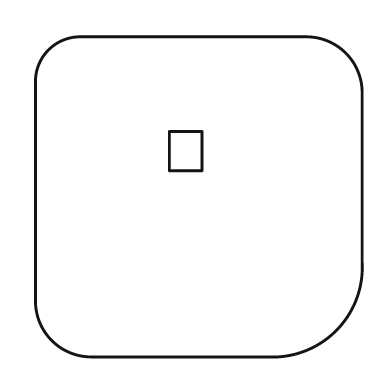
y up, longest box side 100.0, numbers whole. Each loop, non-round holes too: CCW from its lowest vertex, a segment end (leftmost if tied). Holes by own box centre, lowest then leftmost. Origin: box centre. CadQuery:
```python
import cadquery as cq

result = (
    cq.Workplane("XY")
    .moveTo(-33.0, -49.0)
    .lineTo(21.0, -49.0)
    .threePointArc((42.0, -41.0), (50.0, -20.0))
    .lineTo(50.0, 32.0)
    .threePointArc((45.0, 44.0), (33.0, 49.0))
    .lineTo(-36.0, 49.0)
    .threePointArc((-46.0, 45.0), (-50.0, 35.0))
    .lineTo(-50.0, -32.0)
    .threePointArc((-45.0, -44.0), (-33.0, -49.0))
    .close()
    .moveTo(-9.0, 8.0)
    .lineTo(1.0, 8.0)
    .lineTo(1.0, 20.0)
    .lineTo(-9.0, 20.0)
    .close()
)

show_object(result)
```